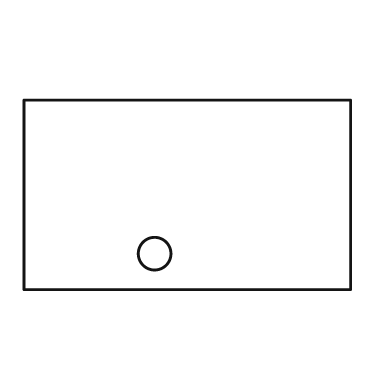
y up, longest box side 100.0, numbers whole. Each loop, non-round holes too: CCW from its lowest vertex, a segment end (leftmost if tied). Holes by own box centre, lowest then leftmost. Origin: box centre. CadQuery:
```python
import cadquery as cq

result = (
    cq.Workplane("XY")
    .moveTo(-50.0, -29.0)
    .lineTo(50.0, -29.0)
    .lineTo(50.0, 29.0)
    .lineTo(-50.0, 29.0)
    .close()
    .moveTo(-10.0, -18.0)
    .circle(5.0)
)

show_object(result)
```